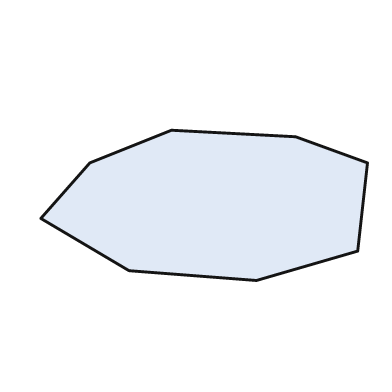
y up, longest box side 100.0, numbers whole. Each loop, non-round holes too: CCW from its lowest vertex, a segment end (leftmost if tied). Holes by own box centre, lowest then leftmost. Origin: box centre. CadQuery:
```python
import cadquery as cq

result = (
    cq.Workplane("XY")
    .moveTo(16.0, -23.0)
    .lineTo(47.0, -14.0)
    .lineTo(50.0, 13.0)
    .lineTo(28.0, 21.0)
    .lineTo(-10.0, 23.0)
    .lineTo(-35.0, 13.0)
    .lineTo(-50.0, -4.0)
    .lineTo(-23.0, -20.0)
    .close()
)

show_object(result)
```